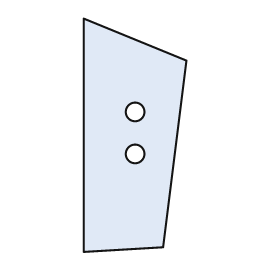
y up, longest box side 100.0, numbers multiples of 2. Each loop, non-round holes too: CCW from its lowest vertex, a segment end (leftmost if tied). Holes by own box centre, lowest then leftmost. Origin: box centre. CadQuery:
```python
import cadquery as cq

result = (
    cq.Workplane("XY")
    .moveTo(-22.0, -50.0)
    .lineTo(12.0, -48.0)
    .lineTo(22.0, 32.0)
    .lineTo(-22.0, 50.0)
    .close()
    .moveTo(0.0, -8.0)
    .circle(4.0)
    .moveTo(0.0, 10.0)
    .circle(4.0)
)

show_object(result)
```